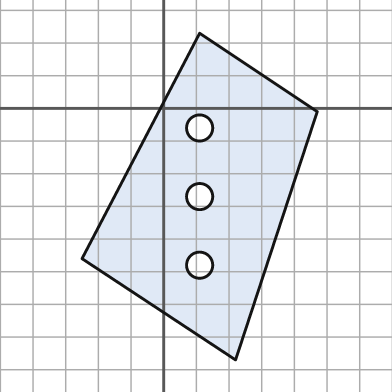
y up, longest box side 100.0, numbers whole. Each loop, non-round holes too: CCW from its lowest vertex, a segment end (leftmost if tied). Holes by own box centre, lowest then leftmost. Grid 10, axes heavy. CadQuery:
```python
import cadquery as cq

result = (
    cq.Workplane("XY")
    .moveTo(22.0, -77.0)
    .lineTo(47.0, -1.0)
    .lineTo(11.0, 23.0)
    .lineTo(-25.0, -46.0)
    .close()
    .moveTo(11.0, -48.0)
    .circle(4.0)
    .moveTo(11.0, -27.0)
    .circle(4.0)
    .moveTo(11.0, -6.0)
    .circle(4.0)
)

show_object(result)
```